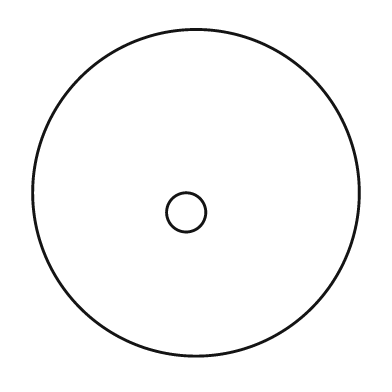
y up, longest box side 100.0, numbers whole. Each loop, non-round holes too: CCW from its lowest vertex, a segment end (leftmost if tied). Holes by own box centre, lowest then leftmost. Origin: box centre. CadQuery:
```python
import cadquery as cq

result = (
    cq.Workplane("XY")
    .moveTo(0.0, 0.0)
    .circle(50.0)
    .moveTo(-3.0, -6.0)
    .circle(6.0)
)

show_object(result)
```